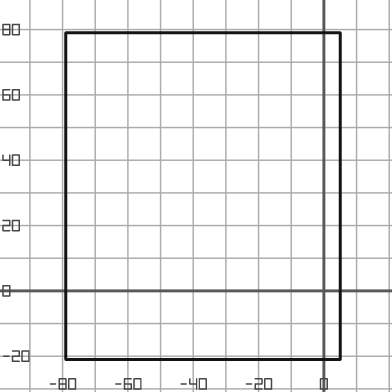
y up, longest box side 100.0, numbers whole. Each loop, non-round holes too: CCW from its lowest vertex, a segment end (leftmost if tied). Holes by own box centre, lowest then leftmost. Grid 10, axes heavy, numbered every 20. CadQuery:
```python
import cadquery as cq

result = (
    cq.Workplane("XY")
    .moveTo(-79.0, -21.0)
    .lineTo(5.0, -21.0)
    .lineTo(5.0, 79.0)
    .lineTo(-79.0, 79.0)
    .close()
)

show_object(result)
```